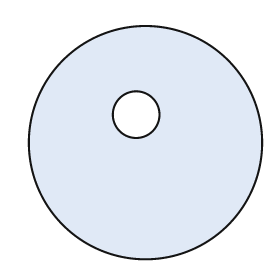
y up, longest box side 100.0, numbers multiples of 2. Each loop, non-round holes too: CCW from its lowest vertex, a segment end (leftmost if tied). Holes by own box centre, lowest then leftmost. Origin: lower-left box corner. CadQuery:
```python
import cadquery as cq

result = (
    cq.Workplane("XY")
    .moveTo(50.0, 50.0)
    .circle(50.0)
    .moveTo(46.0, 62.0)
    .circle(10.0)
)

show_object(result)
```